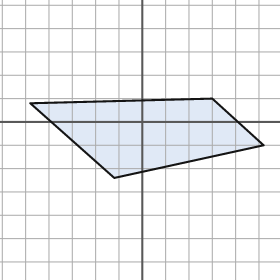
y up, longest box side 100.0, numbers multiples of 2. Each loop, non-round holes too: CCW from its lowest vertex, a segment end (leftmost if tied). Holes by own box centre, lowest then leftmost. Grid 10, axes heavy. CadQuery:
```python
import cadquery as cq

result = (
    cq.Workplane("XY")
    .moveTo(-12.0, -24.0)
    .lineTo(52.0, -10.0)
    .lineTo(30.0, 10.0)
    .lineTo(-48.0, 8.0)
    .close()
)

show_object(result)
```